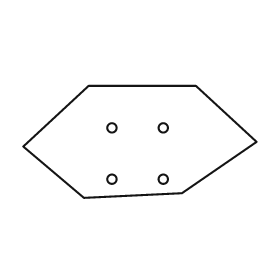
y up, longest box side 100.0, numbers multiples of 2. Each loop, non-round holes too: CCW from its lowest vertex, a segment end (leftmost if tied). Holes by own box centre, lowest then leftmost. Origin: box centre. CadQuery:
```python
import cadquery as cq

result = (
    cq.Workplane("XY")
    .moveTo(-24.0, -24.0)
    .lineTo(18.0, -22.0)
    .lineTo(50.0, 0.0)
    .lineTo(24.0, 24.0)
    .lineTo(-22.0, 24.0)
    .lineTo(-50.0, -2.0)
    .close()
    .moveTo(-12.0, -16.0)
    .circle(2.0)
    .moveTo(10.0, -16.0)
    .circle(2.0)
    .moveTo(-12.0, 6.0)
    .circle(2.0)
    .moveTo(10.0, 6.0)
    .circle(2.0)
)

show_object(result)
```